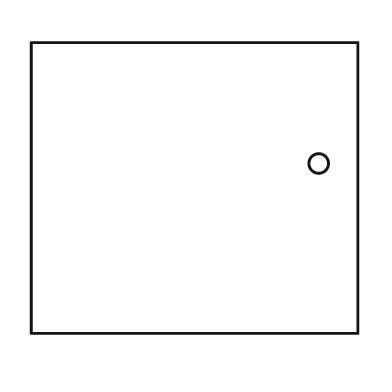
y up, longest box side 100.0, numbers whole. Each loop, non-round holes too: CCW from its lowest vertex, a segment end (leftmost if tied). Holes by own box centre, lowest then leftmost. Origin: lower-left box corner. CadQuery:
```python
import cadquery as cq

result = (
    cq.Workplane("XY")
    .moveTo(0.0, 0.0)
    .lineTo(100.0, 0.0)
    .lineTo(100.0, 89.0)
    .lineTo(0.0, 89.0)
    .close()
    .moveTo(88.0, 52.0)
    .circle(3.0)
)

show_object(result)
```